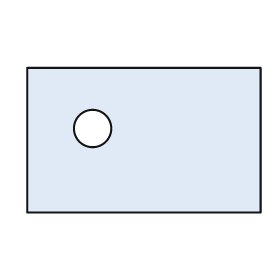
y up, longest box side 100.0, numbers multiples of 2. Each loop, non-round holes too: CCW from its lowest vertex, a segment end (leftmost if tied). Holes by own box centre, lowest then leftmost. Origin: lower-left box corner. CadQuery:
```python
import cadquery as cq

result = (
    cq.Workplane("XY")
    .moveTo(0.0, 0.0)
    .lineTo(100.0, 0.0)
    .lineTo(100.0, 62.0)
    .lineTo(0.0, 62.0)
    .close()
    .moveTo(28.0, 36.0)
    .circle(8.0)
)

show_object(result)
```